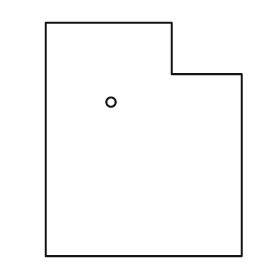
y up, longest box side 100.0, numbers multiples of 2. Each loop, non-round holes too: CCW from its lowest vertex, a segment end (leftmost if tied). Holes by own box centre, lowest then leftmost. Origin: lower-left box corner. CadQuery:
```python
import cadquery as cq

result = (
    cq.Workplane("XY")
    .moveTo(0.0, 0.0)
    .lineTo(84.0, 0.0)
    .lineTo(84.0, 78.0)
    .lineTo(54.0, 78.0)
    .lineTo(54.0, 100.0)
    .lineTo(0.0, 100.0)
    .close()
    .moveTo(28.0, 66.0)
    .circle(2.0)
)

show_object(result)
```